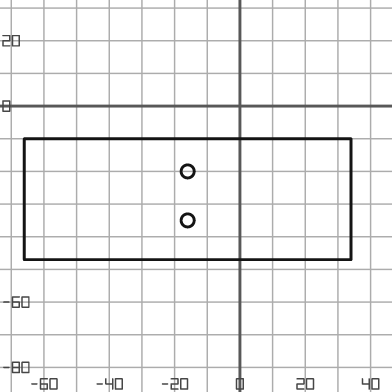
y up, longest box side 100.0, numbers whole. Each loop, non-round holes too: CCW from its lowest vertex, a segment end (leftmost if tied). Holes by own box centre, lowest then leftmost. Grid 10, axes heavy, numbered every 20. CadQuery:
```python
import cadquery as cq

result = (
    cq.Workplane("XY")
    .moveTo(-66.0, -47.0)
    .lineTo(34.0, -47.0)
    .lineTo(34.0, -10.0)
    .lineTo(-66.0, -10.0)
    .close()
    .moveTo(-16.0, -35.0)
    .circle(2.0)
    .moveTo(-16.0, -20.0)
    .circle(2.0)
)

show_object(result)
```